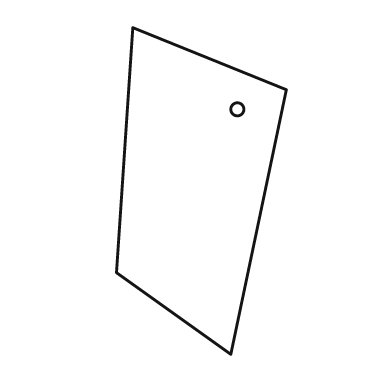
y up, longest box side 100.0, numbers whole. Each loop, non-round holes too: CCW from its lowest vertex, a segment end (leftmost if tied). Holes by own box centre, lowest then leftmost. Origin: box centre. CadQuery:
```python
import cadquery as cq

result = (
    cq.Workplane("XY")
    .moveTo(9.0, -50.0)
    .lineTo(26.0, 31.0)
    .lineTo(-21.0, 50.0)
    .lineTo(-26.0, -25.0)
    .close()
    .moveTo(11.0, 25.0)
    .circle(2.0)
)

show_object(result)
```